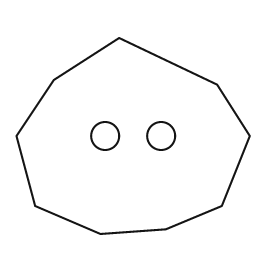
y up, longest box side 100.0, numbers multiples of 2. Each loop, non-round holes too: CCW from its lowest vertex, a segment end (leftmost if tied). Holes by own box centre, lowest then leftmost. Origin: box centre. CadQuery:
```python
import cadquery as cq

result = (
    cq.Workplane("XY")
    .moveTo(-14.0, -42.0)
    .lineTo(14.0, -40.0)
    .lineTo(38.0, -30.0)
    .lineTo(50.0, 0.0)
    .lineTo(36.0, 22.0)
    .lineTo(-6.0, 42.0)
    .lineTo(-34.0, 24.0)
    .lineTo(-50.0, 0.0)
    .lineTo(-42.0, -30.0)
    .close()
    .moveTo(-12.0, 0.0)
    .circle(6.0)
    .moveTo(12.0, 0.0)
    .circle(6.0)
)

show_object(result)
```